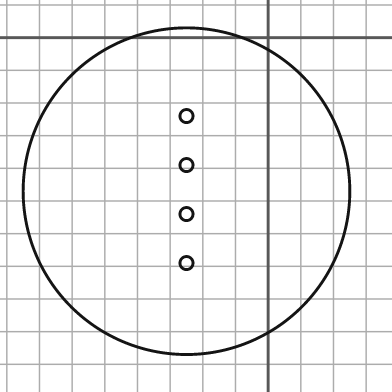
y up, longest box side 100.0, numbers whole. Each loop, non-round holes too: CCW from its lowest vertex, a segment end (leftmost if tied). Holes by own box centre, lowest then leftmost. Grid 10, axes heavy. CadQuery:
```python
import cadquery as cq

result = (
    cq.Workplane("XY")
    .moveTo(-25.0, -47.0)
    .circle(50.0)
    .moveTo(-25.0, -69.0)
    .circle(2.0)
    .moveTo(-25.0, -54.0)
    .circle(2.0)
    .moveTo(-25.0, -39.0)
    .circle(2.0)
    .moveTo(-25.0, -24.0)
    .circle(2.0)
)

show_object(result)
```